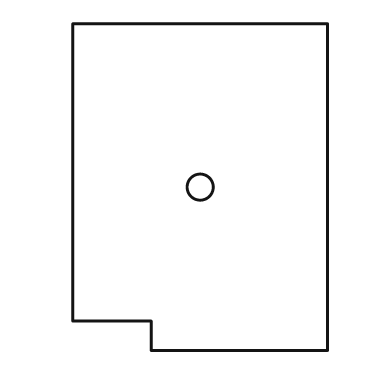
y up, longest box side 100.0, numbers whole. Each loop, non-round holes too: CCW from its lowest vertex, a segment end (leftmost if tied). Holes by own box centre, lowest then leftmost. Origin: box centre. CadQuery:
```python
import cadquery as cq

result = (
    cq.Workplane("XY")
    .moveTo(-15.0, -50.0)
    .lineTo(39.0, -50.0)
    .lineTo(39.0, 50.0)
    .lineTo(-39.0, 50.0)
    .lineTo(-39.0, -41.0)
    .lineTo(-15.0, -41.0)
    .close()
    .moveTo(0.0, 0.0)
    .circle(4.0)
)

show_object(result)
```